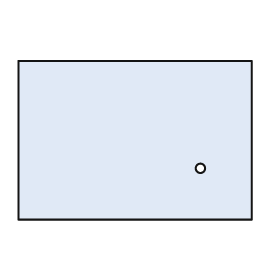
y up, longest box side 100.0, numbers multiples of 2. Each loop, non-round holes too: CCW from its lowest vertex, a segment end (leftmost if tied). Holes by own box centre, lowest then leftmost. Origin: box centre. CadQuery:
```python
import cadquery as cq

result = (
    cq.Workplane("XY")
    .moveTo(-50.0, -34.0)
    .lineTo(50.0, -34.0)
    .lineTo(50.0, 34.0)
    .lineTo(-50.0, 34.0)
    .close()
    .moveTo(28.0, -12.0)
    .circle(2.0)
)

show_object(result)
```